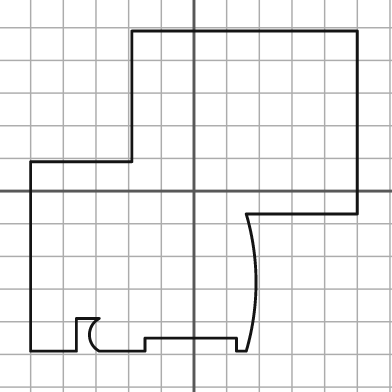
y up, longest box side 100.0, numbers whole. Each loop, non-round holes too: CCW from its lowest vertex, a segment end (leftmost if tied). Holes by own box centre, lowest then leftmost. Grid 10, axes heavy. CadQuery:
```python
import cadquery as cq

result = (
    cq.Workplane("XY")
    .moveTo(-50.0, -49.0)
    .lineTo(-36.0, -49.0)
    .lineTo(-36.0, -39.0)
    .lineTo(-29.0, -39.0)
    .threePointArc((-32.0, -44.0), (-29.0, -49.0))
    .lineTo(-15.0, -49.0)
    .lineTo(-15.0, -45.0)
    .lineTo(13.0, -45.0)
    .lineTo(13.0, -49.0)
    .lineTo(16.0, -49.0)
    .threePointArc((19.0, -28.0), (16.0, -7.0))
    .lineTo(50.0, -7.0)
    .lineTo(50.0, 49.0)
    .lineTo(-19.0, 49.0)
    .lineTo(-19.0, 9.0)
    .lineTo(-50.0, 9.0)
    .close()
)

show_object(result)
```